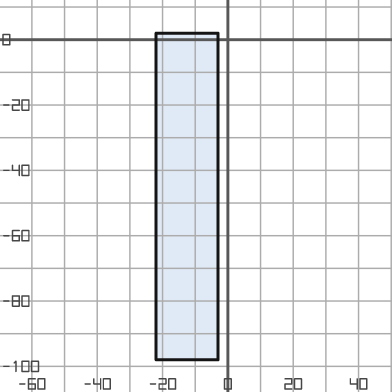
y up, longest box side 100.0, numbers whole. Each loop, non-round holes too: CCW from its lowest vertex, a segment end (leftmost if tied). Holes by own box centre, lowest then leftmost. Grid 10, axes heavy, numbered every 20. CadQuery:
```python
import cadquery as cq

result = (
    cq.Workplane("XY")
    .moveTo(-22.0, -98.0)
    .lineTo(-3.0, -98.0)
    .lineTo(-3.0, 2.0)
    .lineTo(-22.0, 2.0)
    .close()
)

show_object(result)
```